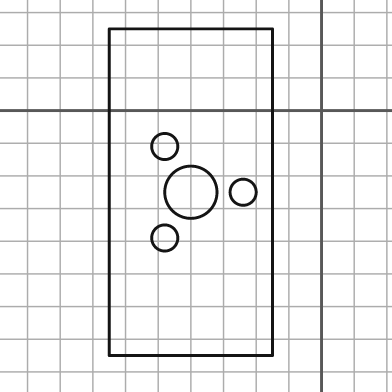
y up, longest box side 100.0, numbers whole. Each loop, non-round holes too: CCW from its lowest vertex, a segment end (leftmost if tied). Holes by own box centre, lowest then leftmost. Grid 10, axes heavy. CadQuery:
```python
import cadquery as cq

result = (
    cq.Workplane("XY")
    .moveTo(-65.0, -75.0)
    .lineTo(-15.0, -75.0)
    .lineTo(-15.0, 25.0)
    .lineTo(-65.0, 25.0)
    .close()
    .moveTo(-48.0, -39.0)
    .circle(4.0)
    .moveTo(-40.0, -25.0)
    .circle(8.0)
    .moveTo(-24.0, -25.0)
    .circle(4.0)
    .moveTo(-48.0, -11.0)
    .circle(4.0)
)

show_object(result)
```